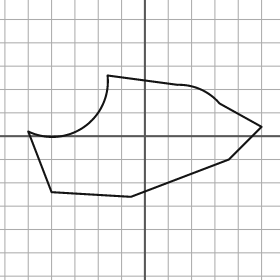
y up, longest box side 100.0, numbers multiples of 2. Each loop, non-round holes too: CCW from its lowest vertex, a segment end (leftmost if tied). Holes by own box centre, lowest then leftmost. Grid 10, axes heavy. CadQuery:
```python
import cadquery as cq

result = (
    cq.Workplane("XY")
    .moveTo(-6.0, -26.0)
    .lineTo(36.0, -10.0)
    .lineTo(50.0, 4.0)
    .lineTo(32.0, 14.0)
    .threePointArc((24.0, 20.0), (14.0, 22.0))
    .lineTo(-16.0, 26.0)
    .threePointArc((-26.0, 4.0), (-50.0, 2.0))
    .lineTo(-40.0, -24.0)
    .close()
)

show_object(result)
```